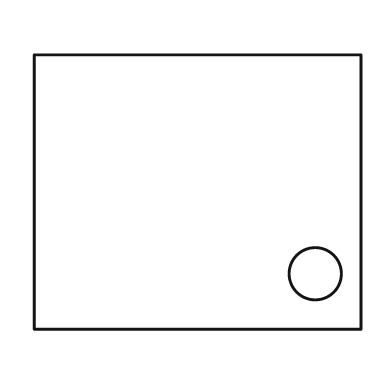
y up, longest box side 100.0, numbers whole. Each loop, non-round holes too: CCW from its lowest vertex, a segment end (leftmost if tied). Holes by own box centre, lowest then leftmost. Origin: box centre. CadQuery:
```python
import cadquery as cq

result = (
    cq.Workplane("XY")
    .moveTo(-50.0, -42.0)
    .lineTo(50.0, -42.0)
    .lineTo(50.0, 42.0)
    .lineTo(-50.0, 42.0)
    .close()
    .moveTo(36.0, -25.0)
    .circle(8.0)
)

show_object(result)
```